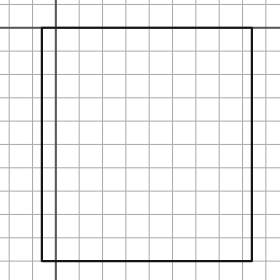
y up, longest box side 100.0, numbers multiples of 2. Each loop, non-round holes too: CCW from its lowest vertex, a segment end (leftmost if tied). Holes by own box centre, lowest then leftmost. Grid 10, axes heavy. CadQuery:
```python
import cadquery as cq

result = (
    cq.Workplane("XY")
    .moveTo(-6.0, -100.0)
    .lineTo(84.0, -100.0)
    .lineTo(84.0, 0.0)
    .lineTo(-6.0, 0.0)
    .close()
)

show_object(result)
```